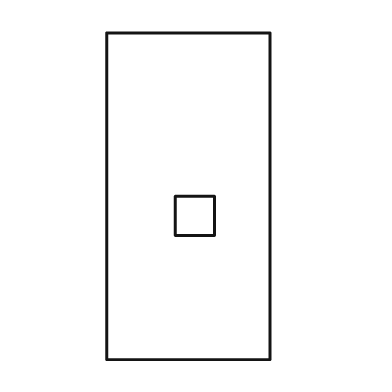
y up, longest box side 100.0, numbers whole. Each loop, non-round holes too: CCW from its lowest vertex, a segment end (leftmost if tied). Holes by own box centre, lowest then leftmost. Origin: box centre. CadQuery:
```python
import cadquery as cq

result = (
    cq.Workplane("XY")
    .moveTo(-25.0, -50.0)
    .lineTo(25.0, -50.0)
    .lineTo(25.0, 50.0)
    .lineTo(-25.0, 50.0)
    .close()
    .moveTo(-4.0, -12.0)
    .lineTo(8.0, -12.0)
    .lineTo(8.0, 0.0)
    .lineTo(-4.0, 0.0)
    .close()
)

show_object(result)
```